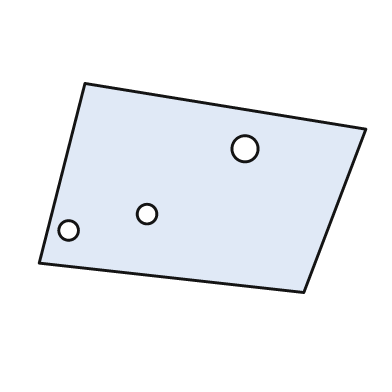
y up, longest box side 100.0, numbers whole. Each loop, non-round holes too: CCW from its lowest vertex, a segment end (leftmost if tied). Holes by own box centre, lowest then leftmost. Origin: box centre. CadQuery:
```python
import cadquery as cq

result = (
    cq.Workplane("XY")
    .moveTo(31.0, -32.0)
    .lineTo(50.0, 18.0)
    .lineTo(-36.0, 32.0)
    .lineTo(-50.0, -23.0)
    .close()
    .moveTo(-41.0, -13.0)
    .circle(3.0)
    .moveTo(-17.0, -8.0)
    .circle(3.0)
    .moveTo(13.0, 12.0)
    .circle(4.0)
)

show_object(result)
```